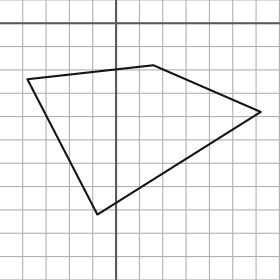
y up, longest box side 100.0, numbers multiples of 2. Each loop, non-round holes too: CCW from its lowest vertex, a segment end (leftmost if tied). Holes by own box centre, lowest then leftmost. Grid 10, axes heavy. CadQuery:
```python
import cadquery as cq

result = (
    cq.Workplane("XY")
    .moveTo(-8.0, -82.0)
    .lineTo(62.0, -38.0)
    .lineTo(16.0, -18.0)
    .lineTo(-38.0, -24.0)
    .close()
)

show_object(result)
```